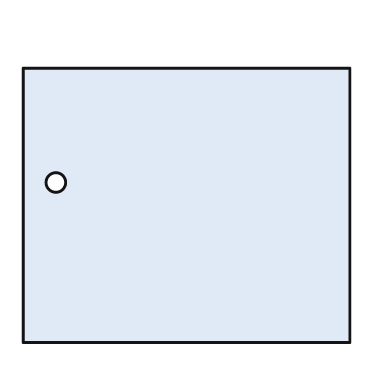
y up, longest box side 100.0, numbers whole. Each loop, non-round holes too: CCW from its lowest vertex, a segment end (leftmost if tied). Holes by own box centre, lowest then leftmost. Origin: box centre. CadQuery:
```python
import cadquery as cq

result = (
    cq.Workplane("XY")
    .moveTo(-50.0, -42.0)
    .lineTo(50.0, -42.0)
    .lineTo(50.0, 42.0)
    .lineTo(-50.0, 42.0)
    .close()
    .moveTo(-40.0, 7.0)
    .circle(3.0)
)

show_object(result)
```